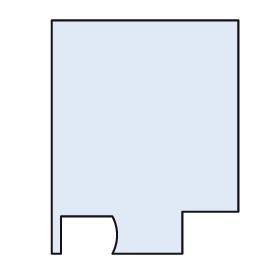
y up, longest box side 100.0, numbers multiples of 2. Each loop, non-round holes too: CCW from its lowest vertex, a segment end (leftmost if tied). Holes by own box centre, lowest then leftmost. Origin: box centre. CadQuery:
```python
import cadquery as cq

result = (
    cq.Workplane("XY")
    .moveTo(-40.0, -50.0)
    .lineTo(-36.0, -50.0)
    .lineTo(-36.0, -34.0)
    .lineTo(-14.0, -34.0)
    .threePointArc((-12.0, -42.0), (-14.0, -50.0))
    .lineTo(16.0, -50.0)
    .lineTo(16.0, -32.0)
    .lineTo(40.0, -32.0)
    .lineTo(40.0, 50.0)
    .lineTo(-40.0, 50.0)
    .close()
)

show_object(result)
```